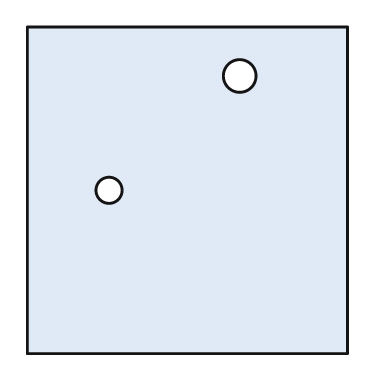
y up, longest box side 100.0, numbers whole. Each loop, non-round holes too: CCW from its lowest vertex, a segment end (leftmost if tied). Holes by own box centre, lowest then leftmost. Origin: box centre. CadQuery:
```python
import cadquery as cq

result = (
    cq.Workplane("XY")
    .moveTo(-49.0, -50.0)
    .lineTo(49.0, -50.0)
    .lineTo(49.0, 50.0)
    .lineTo(-49.0, 50.0)
    .close()
    .moveTo(-24.0, 0.0)
    .circle(4.0)
    .moveTo(16.0, 35.0)
    .circle(5.0)
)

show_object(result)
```